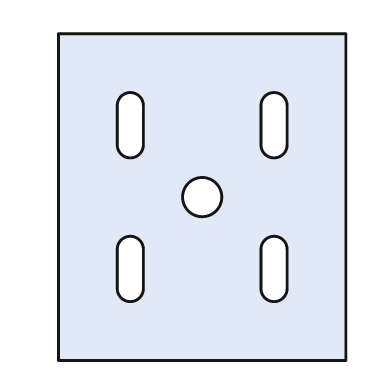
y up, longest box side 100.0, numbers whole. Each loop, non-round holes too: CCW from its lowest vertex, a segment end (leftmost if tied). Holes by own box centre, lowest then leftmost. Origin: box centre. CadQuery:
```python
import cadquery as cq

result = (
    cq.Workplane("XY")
    .moveTo(-44.0, -50.0)
    .lineTo(44.0, -50.0)
    .lineTo(44.0, 50.0)
    .lineTo(-44.0, 50.0)
    .close()
    .moveTo(-26.0, -28.0)
    .threePointArc((-22.0, -32.0), (-18.0, -28.0))
    .lineTo(-18.0, -16.0)
    .threePointArc((-22.0, -12.0), (-26.0, -16.0))
    .close()
    .moveTo(18.0, -28.0)
    .threePointArc((22.0, -32.0), (26.0, -28.0))
    .lineTo(26.0, -16.0)
    .threePointArc((22.0, -12.0), (18.0, -16.0))
    .close()
    .moveTo(0.0, 0.0)
    .circle(6.0)
    .moveTo(-26.0, 16.0)
    .threePointArc((-22.0, 12.0), (-18.0, 16.0))
    .lineTo(-18.0, 28.0)
    .threePointArc((-22.0, 32.0), (-26.0, 28.0))
    .close()
    .moveTo(18.0, 16.0)
    .threePointArc((22.0, 12.0), (26.0, 16.0))
    .lineTo(26.0, 28.0)
    .threePointArc((22.0, 32.0), (18.0, 28.0))
    .close()
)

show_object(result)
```